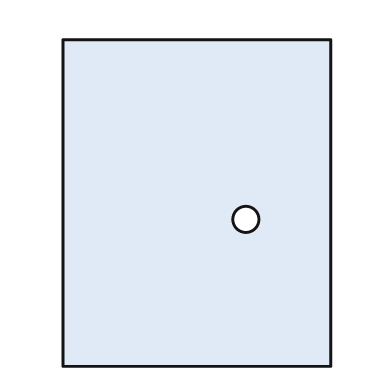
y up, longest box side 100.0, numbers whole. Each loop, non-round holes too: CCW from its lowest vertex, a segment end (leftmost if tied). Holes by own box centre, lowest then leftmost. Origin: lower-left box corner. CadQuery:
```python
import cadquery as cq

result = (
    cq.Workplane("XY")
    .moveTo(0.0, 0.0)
    .lineTo(82.0, 0.0)
    .lineTo(82.0, 100.0)
    .lineTo(0.0, 100.0)
    .close()
    .moveTo(56.0, 45.0)
    .circle(4.0)
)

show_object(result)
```